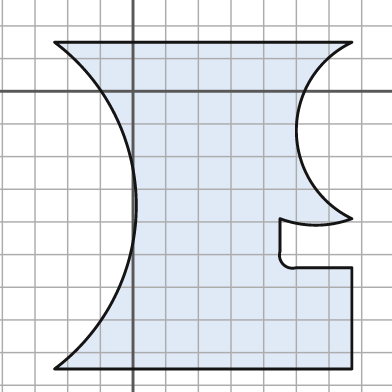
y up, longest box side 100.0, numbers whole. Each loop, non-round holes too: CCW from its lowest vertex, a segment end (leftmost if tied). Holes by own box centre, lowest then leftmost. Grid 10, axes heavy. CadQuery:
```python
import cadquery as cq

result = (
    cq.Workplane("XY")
    .moveTo(-24.0, -85.0)
    .lineTo(67.0, -85.0)
    .lineTo(67.0, -54.0)
    .lineTo(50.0, -54.0)
    .threePointArc((46.0, -53.0), (45.0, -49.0))
    .lineTo(45.0, -39.0)
    .threePointArc((56.0, -41.0), (67.0, -39.0))
    .threePointArc((50.0, -12.0), (67.0, 15.0))
    .lineTo(-24.0, 15.0)
    .threePointArc((1.0, -35.0), (-24.0, -85.0))
    .close()
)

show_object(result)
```